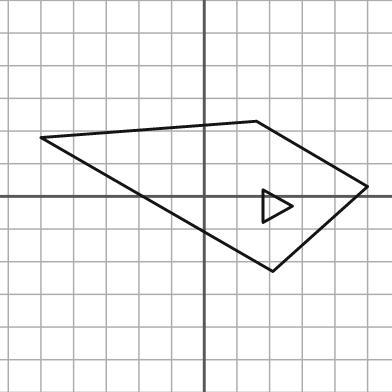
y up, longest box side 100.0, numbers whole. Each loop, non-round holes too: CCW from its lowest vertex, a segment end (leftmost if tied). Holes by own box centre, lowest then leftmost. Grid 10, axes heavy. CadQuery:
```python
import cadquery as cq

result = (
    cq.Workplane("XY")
    .moveTo(21.0, -23.0)
    .lineTo(50.0, 3.0)
    .lineTo(16.0, 23.0)
    .lineTo(-50.0, 18.0)
    .close()
    .moveTo(18.0, -8.0)
    .lineTo(27.0, -3.0)
    .lineTo(18.0, 2.0)
    .close()
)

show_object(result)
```